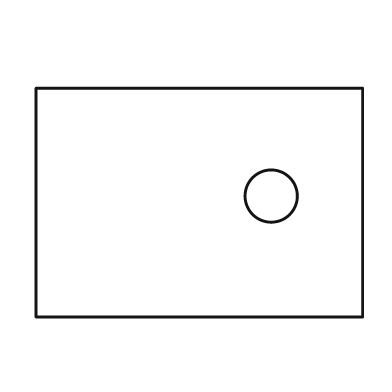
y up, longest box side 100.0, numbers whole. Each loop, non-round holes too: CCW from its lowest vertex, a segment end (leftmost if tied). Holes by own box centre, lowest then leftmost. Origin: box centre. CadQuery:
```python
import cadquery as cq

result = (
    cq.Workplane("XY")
    .moveTo(-50.0, -35.0)
    .lineTo(50.0, -35.0)
    .lineTo(50.0, 35.0)
    .lineTo(-50.0, 35.0)
    .close()
    .moveTo(22.0, 2.0)
    .circle(8.0)
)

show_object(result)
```